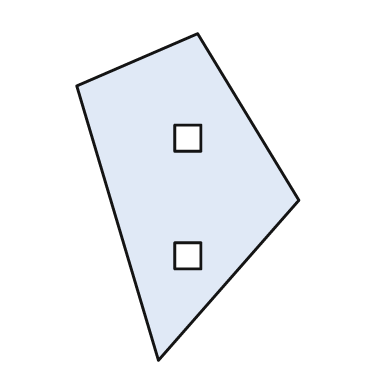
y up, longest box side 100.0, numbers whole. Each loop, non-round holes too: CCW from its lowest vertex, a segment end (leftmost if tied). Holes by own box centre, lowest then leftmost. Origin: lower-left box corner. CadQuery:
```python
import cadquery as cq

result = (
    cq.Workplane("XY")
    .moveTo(25.0, 0.0)
    .lineTo(68.0, 49.0)
    .lineTo(37.0, 100.0)
    .lineTo(0.0, 84.0)
    .close()
    .moveTo(30.0, 28.0)
    .lineTo(38.0, 28.0)
    .lineTo(38.0, 36.0)
    .lineTo(30.0, 36.0)
    .close()
    .moveTo(30.0, 64.0)
    .lineTo(38.0, 64.0)
    .lineTo(38.0, 72.0)
    .lineTo(30.0, 72.0)
    .close()
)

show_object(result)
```